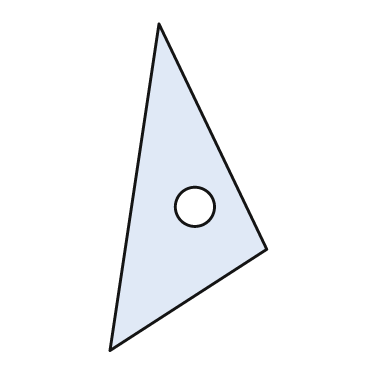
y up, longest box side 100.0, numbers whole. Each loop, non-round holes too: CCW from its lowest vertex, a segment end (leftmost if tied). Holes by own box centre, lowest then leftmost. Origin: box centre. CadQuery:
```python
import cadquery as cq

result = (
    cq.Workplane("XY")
    .moveTo(-24.0, -50.0)
    .lineTo(24.0, -19.0)
    .lineTo(-9.0, 50.0)
    .close()
    .moveTo(2.0, -6.0)
    .circle(6.0)
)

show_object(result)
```